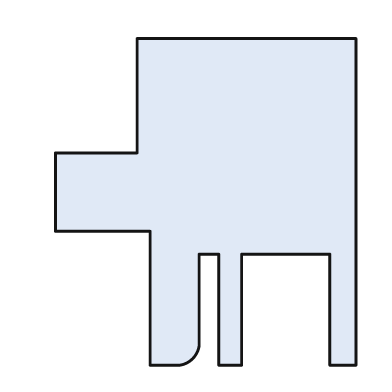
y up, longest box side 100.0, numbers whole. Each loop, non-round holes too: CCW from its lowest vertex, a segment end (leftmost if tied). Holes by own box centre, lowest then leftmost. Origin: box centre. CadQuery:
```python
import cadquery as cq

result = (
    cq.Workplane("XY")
    .moveTo(-17.0, -50.0)
    .lineTo(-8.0, -50.0)
    .threePointArc((-4.0, -48.0), (-2.0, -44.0))
    .lineTo(-2.0, -16.0)
    .lineTo(4.0, -16.0)
    .lineTo(4.0, -50.0)
    .lineTo(11.0, -50.0)
    .lineTo(11.0, -16.0)
    .lineTo(38.0, -16.0)
    .lineTo(38.0, -50.0)
    .lineTo(46.0, -50.0)
    .lineTo(46.0, 50.0)
    .lineTo(-21.0, 50.0)
    .lineTo(-21.0, 15.0)
    .lineTo(-46.0, 15.0)
    .lineTo(-46.0, -9.0)
    .lineTo(-17.0, -9.0)
    .close()
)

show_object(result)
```